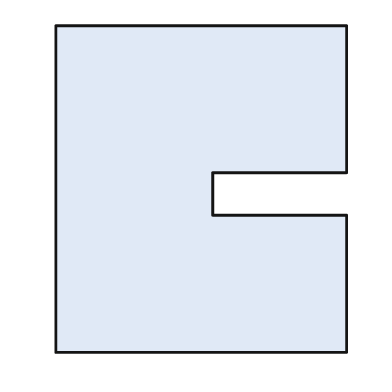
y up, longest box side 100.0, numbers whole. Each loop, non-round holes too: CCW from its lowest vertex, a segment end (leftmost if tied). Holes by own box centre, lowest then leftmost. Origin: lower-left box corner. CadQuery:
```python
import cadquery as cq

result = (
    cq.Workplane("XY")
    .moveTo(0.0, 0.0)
    .lineTo(89.0, 0.0)
    .lineTo(89.0, 42.0)
    .lineTo(48.0, 42.0)
    .lineTo(48.0, 55.0)
    .lineTo(89.0, 55.0)
    .lineTo(89.0, 100.0)
    .lineTo(0.0, 100.0)
    .close()
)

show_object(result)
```